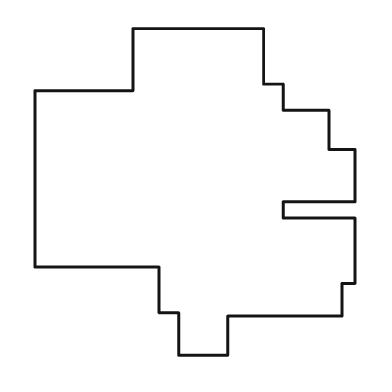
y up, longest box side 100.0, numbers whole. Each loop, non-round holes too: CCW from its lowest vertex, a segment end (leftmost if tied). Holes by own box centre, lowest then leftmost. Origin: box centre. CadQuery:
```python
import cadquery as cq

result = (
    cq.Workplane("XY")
    .moveTo(-5.0, -50.0)
    .lineTo(10.0, -50.0)
    .lineTo(10.0, -38.0)
    .lineTo(45.0, -38.0)
    .lineTo(45.0, -28.0)
    .lineTo(49.0, -28.0)
    .lineTo(49.0, -8.0)
    .lineTo(27.0, -8.0)
    .lineTo(27.0, -3.0)
    .lineTo(49.0, -3.0)
    .lineTo(49.0, 13.0)
    .lineTo(41.0, 13.0)
    .lineTo(41.0, 25.0)
    .lineTo(27.0, 25.0)
    .lineTo(27.0, 33.0)
    .lineTo(21.0, 33.0)
    .lineTo(21.0, 50.0)
    .lineTo(-19.0, 50.0)
    .lineTo(-19.0, 31.0)
    .lineTo(-49.0, 31.0)
    .lineTo(-49.0, -23.0)
    .lineTo(-11.0, -23.0)
    .lineTo(-11.0, -37.0)
    .lineTo(-5.0, -37.0)
    .close()
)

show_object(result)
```